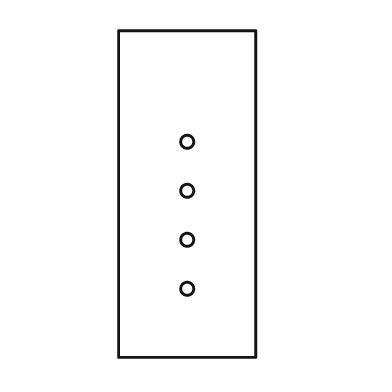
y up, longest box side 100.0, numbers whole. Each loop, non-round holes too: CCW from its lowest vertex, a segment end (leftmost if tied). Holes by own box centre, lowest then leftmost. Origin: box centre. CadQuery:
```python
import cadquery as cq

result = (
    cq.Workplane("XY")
    .moveTo(-21.0, -50.0)
    .lineTo(21.0, -50.0)
    .lineTo(21.0, 50.0)
    .lineTo(-21.0, 50.0)
    .close()
    .moveTo(0.0, -29.0)
    .circle(2.0)
    .moveTo(0.0, -14.0)
    .circle(2.0)
    .moveTo(0.0, 1.0)
    .circle(2.0)
    .moveTo(0.0, 16.0)
    .circle(2.0)
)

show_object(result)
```